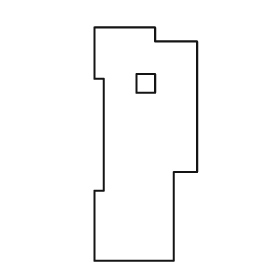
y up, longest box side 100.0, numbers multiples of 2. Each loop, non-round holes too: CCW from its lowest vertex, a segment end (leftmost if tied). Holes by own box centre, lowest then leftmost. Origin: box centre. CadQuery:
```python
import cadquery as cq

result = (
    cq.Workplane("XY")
    .moveTo(-22.0, -50.0)
    .lineTo(12.0, -50.0)
    .lineTo(12.0, -12.0)
    .lineTo(22.0, -12.0)
    .lineTo(22.0, 44.0)
    .lineTo(4.0, 44.0)
    .lineTo(4.0, 50.0)
    .lineTo(-22.0, 50.0)
    .lineTo(-22.0, 28.0)
    .lineTo(-18.0, 28.0)
    .lineTo(-18.0, -20.0)
    .lineTo(-22.0, -20.0)
    .close()
    .moveTo(-4.0, 22.0)
    .lineTo(4.0, 22.0)
    .lineTo(4.0, 30.0)
    .lineTo(-4.0, 30.0)
    .close()
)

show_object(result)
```